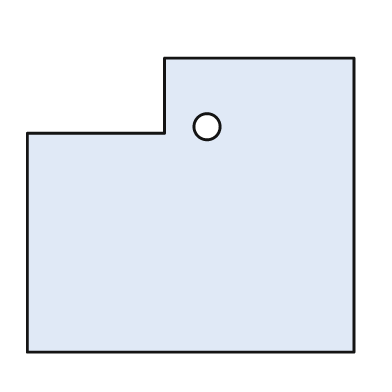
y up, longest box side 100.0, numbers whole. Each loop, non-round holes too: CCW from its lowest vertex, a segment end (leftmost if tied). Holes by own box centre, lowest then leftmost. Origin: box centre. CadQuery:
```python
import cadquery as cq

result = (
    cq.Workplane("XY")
    .moveTo(-50.0, -45.0)
    .lineTo(50.0, -45.0)
    .lineTo(50.0, 45.0)
    .lineTo(-8.0, 45.0)
    .lineTo(-8.0, 22.0)
    .lineTo(-50.0, 22.0)
    .close()
    .moveTo(5.0, 24.0)
    .circle(4.0)
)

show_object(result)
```